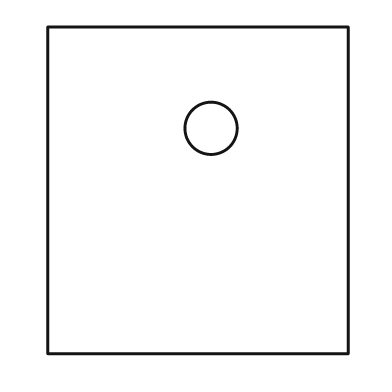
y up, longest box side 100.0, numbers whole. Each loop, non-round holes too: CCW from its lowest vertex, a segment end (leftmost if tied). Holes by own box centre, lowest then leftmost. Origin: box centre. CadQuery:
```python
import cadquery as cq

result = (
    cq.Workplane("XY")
    .moveTo(-46.0, -50.0)
    .lineTo(46.0, -50.0)
    .lineTo(46.0, 50.0)
    .lineTo(-46.0, 50.0)
    .close()
    .moveTo(4.0, 19.0)
    .circle(8.0)
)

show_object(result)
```